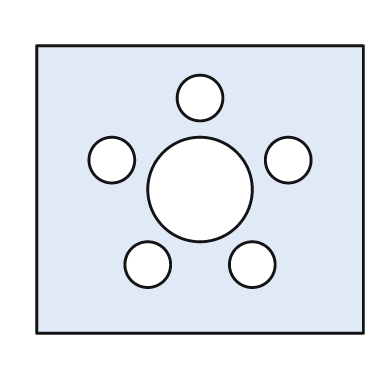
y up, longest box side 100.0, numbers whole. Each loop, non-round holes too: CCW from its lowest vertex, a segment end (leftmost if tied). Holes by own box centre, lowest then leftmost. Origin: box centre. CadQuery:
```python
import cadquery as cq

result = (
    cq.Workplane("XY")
    .moveTo(-50.0, -44.0)
    .lineTo(50.0, -44.0)
    .lineTo(50.0, 44.0)
    .lineTo(-50.0, 44.0)
    .close()
    .moveTo(-16.0, -23.0)
    .circle(7.0)
    .moveTo(16.0, -23.0)
    .circle(7.0)
    .moveTo(0.0, 0.0)
    .circle(16.0)
    .moveTo(-27.0, 9.0)
    .circle(7.0)
    .moveTo(27.0, 9.0)
    .circle(7.0)
    .moveTo(0.0, 28.0)
    .circle(7.0)
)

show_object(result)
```